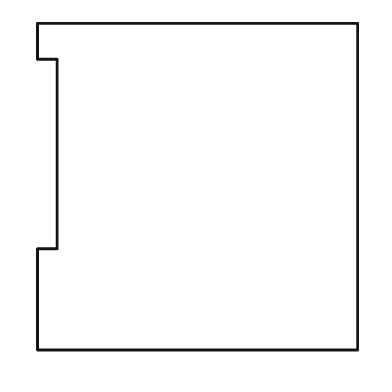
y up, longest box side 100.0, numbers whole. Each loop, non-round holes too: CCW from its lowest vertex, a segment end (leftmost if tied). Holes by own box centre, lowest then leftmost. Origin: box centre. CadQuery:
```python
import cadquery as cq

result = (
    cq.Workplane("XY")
    .moveTo(-49.0, -50.0)
    .lineTo(49.0, -50.0)
    .lineTo(49.0, 50.0)
    .lineTo(-49.0, 50.0)
    .lineTo(-49.0, 39.0)
    .lineTo(-43.0, 39.0)
    .lineTo(-43.0, -19.0)
    .lineTo(-49.0, -19.0)
    .close()
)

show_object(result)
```